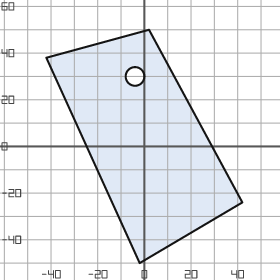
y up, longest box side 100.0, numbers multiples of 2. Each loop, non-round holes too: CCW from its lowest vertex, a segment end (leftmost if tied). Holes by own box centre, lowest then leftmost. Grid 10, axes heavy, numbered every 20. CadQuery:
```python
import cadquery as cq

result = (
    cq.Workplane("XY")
    .moveTo(-2.0, -50.0)
    .lineTo(42.0, -24.0)
    .lineTo(2.0, 50.0)
    .lineTo(-42.0, 38.0)
    .close()
    .moveTo(-4.0, 30.0)
    .circle(4.0)
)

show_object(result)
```